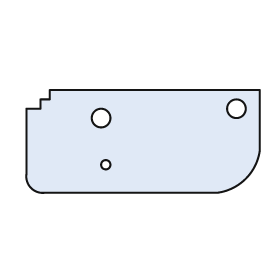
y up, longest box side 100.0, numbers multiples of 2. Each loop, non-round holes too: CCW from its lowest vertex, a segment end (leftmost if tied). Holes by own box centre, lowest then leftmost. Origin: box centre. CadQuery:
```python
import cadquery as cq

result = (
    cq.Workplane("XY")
    .moveTo(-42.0, -22.0)
    .lineTo(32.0, -22.0)
    .threePointArc((44.0, -16.0), (50.0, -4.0))
    .lineTo(50.0, 22.0)
    .lineTo(-40.0, 22.0)
    .lineTo(-40.0, 18.0)
    .lineTo(-44.0, 18.0)
    .lineTo(-44.0, 14.0)
    .lineTo(-50.0, 14.0)
    .lineTo(-50.0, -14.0)
    .threePointArc((-48.0, -20.0), (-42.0, -22.0))
    .close()
    .moveTo(-16.0, -10.0)
    .circle(2.0)
    .moveTo(-18.0, 10.0)
    .circle(4.0)
    .moveTo(40.0, 14.0)
    .circle(4.0)
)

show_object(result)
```